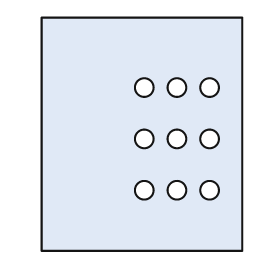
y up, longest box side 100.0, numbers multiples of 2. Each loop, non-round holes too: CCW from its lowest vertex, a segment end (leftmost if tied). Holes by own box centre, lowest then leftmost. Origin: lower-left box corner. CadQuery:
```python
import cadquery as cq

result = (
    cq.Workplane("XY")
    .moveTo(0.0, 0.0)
    .lineTo(86.0, 0.0)
    .lineTo(86.0, 100.0)
    .lineTo(0.0, 100.0)
    .close()
    .moveTo(44.0, 26.0)
    .circle(4.0)
    .moveTo(58.0, 26.0)
    .circle(4.0)
    .moveTo(72.0, 26.0)
    .circle(4.0)
    .moveTo(44.0, 48.0)
    .circle(4.0)
    .moveTo(58.0, 48.0)
    .circle(4.0)
    .moveTo(72.0, 48.0)
    .circle(4.0)
    .moveTo(44.0, 70.0)
    .circle(4.0)
    .moveTo(58.0, 70.0)
    .circle(4.0)
    .moveTo(72.0, 70.0)
    .circle(4.0)
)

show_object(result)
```